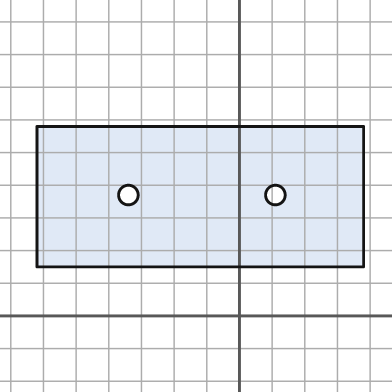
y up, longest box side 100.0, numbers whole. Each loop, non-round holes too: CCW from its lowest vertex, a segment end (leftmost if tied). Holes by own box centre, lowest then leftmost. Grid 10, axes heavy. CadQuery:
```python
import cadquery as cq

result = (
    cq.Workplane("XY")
    .moveTo(-62.0, 15.0)
    .lineTo(38.0, 15.0)
    .lineTo(38.0, 58.0)
    .lineTo(-62.0, 58.0)
    .close()
    .moveTo(-34.0, 37.0)
    .circle(3.0)
    .moveTo(11.0, 37.0)
    .circle(3.0)
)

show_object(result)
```